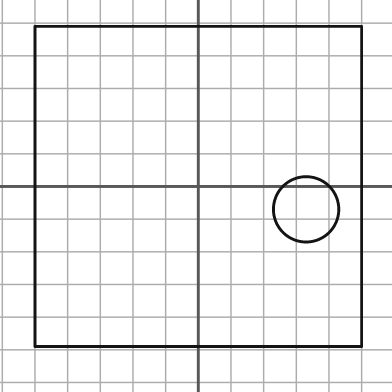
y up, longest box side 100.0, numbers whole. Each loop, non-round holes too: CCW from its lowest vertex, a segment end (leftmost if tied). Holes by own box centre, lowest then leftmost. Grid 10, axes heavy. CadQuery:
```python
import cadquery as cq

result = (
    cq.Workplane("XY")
    .moveTo(-50.0, -49.0)
    .lineTo(50.0, -49.0)
    .lineTo(50.0, 49.0)
    .lineTo(-50.0, 49.0)
    .close()
    .moveTo(33.0, -7.0)
    .circle(10.0)
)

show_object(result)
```